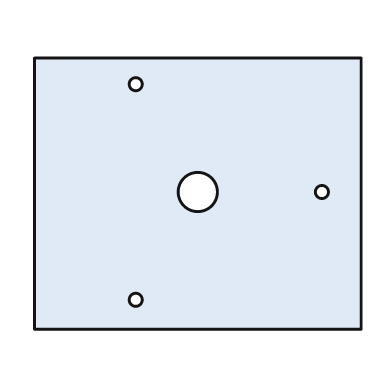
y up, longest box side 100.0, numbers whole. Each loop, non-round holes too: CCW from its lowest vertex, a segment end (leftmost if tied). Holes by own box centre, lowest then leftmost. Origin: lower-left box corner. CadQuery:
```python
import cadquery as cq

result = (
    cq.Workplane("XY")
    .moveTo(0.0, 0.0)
    .lineTo(100.0, 0.0)
    .lineTo(100.0, 83.0)
    .lineTo(0.0, 83.0)
    .close()
    .moveTo(31.0, 9.0)
    .circle(2.0)
    .moveTo(50.0, 42.0)
    .circle(6.0)
    .moveTo(88.0, 42.0)
    .circle(2.0)
    .moveTo(31.0, 75.0)
    .circle(2.0)
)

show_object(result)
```